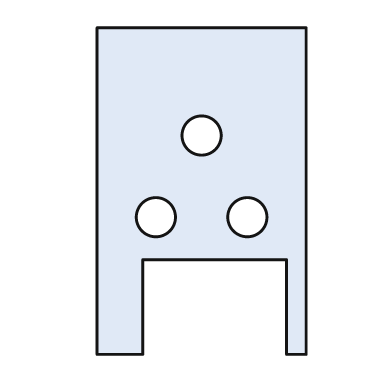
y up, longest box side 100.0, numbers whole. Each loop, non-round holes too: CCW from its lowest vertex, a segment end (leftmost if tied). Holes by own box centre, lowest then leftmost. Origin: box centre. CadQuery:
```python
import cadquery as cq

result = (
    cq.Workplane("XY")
    .moveTo(-32.0, -50.0)
    .lineTo(-18.0, -50.0)
    .lineTo(-18.0, -21.0)
    .lineTo(26.0, -21.0)
    .lineTo(26.0, -50.0)
    .lineTo(32.0, -50.0)
    .lineTo(32.0, 50.0)
    .lineTo(-32.0, 50.0)
    .close()
    .moveTo(-14.0, -8.0)
    .circle(6.0)
    .moveTo(14.0, -8.0)
    .circle(6.0)
    .moveTo(0.0, 17.0)
    .circle(6.0)
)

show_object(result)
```